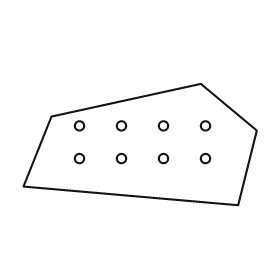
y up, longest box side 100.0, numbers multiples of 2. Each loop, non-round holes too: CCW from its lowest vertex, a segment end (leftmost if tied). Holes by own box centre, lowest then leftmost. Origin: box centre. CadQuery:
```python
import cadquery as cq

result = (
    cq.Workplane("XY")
    .moveTo(42.0, -26.0)
    .lineTo(50.0, 6.0)
    .lineTo(26.0, 26.0)
    .lineTo(-38.0, 12.0)
    .lineTo(-50.0, -18.0)
    .close()
    .moveTo(-26.0, -6.0)
    .circle(2.0)
    .moveTo(-8.0, -6.0)
    .circle(2.0)
    .moveTo(10.0, -6.0)
    .circle(2.0)
    .moveTo(28.0, -6.0)
    .circle(2.0)
    .moveTo(-26.0, 8.0)
    .circle(2.0)
    .moveTo(-8.0, 8.0)
    .circle(2.0)
    .moveTo(10.0, 8.0)
    .circle(2.0)
    .moveTo(28.0, 8.0)
    .circle(2.0)
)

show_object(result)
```